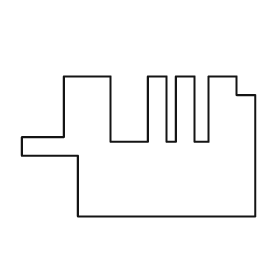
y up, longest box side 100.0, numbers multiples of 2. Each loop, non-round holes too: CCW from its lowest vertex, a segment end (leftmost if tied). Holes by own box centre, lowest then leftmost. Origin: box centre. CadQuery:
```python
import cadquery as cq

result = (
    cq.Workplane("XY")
    .moveTo(-26.0, -30.0)
    .lineTo(50.0, -30.0)
    .lineTo(50.0, 22.0)
    .lineTo(42.0, 22.0)
    .lineTo(42.0, 30.0)
    .lineTo(30.0, 30.0)
    .lineTo(30.0, 2.0)
    .lineTo(24.0, 2.0)
    .lineTo(24.0, 30.0)
    .lineTo(16.0, 30.0)
    .lineTo(16.0, 2.0)
    .lineTo(12.0, 2.0)
    .lineTo(12.0, 30.0)
    .lineTo(4.0, 30.0)
    .lineTo(4.0, 2.0)
    .lineTo(-12.0, 2.0)
    .lineTo(-12.0, 30.0)
    .lineTo(-32.0, 30.0)
    .lineTo(-32.0, 4.0)
    .lineTo(-50.0, 4.0)
    .lineTo(-50.0, -4.0)
    .lineTo(-26.0, -4.0)
    .close()
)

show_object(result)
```